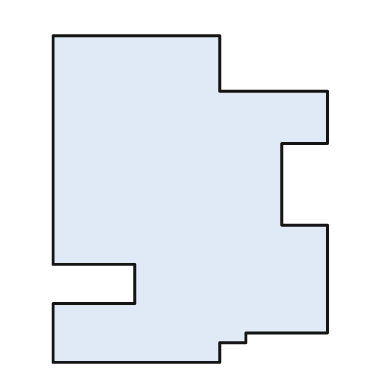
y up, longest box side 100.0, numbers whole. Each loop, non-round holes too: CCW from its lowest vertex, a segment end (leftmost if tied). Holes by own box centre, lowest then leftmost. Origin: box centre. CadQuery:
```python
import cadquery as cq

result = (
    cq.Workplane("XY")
    .moveTo(-42.0, -50.0)
    .lineTo(9.0, -50.0)
    .lineTo(9.0, -44.0)
    .lineTo(17.0, -44.0)
    .lineTo(17.0, -41.0)
    .lineTo(42.0, -41.0)
    .lineTo(42.0, -8.0)
    .lineTo(28.0, -8.0)
    .lineTo(28.0, 17.0)
    .lineTo(42.0, 17.0)
    .lineTo(42.0, 33.0)
    .lineTo(9.0, 33.0)
    .lineTo(9.0, 50.0)
    .lineTo(-42.0, 50.0)
    .lineTo(-42.0, -20.0)
    .lineTo(-17.0, -20.0)
    .lineTo(-17.0, -32.0)
    .lineTo(-42.0, -32.0)
    .close()
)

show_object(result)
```